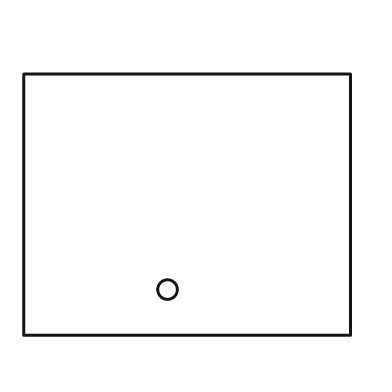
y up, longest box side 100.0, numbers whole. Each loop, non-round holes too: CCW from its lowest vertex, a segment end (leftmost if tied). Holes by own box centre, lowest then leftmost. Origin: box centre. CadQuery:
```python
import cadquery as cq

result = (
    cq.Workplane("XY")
    .moveTo(-50.0, -40.0)
    .lineTo(50.0, -40.0)
    .lineTo(50.0, 40.0)
    .lineTo(-50.0, 40.0)
    .close()
    .moveTo(-6.0, -26.0)
    .circle(3.0)
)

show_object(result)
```